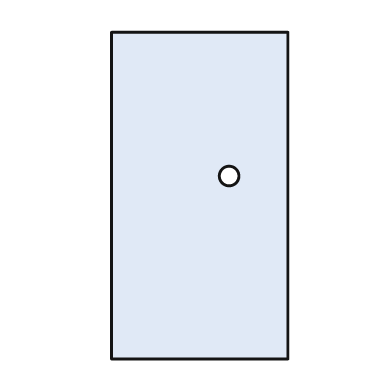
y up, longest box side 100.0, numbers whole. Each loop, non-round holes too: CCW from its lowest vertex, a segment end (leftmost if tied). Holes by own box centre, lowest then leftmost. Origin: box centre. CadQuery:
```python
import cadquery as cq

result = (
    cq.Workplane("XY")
    .moveTo(-27.0, -50.0)
    .lineTo(27.0, -50.0)
    .lineTo(27.0, 50.0)
    .lineTo(-27.0, 50.0)
    .close()
    .moveTo(9.0, 6.0)
    .circle(3.0)
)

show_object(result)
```